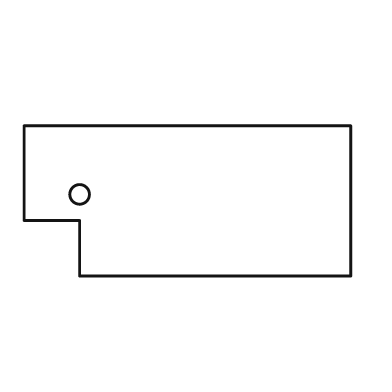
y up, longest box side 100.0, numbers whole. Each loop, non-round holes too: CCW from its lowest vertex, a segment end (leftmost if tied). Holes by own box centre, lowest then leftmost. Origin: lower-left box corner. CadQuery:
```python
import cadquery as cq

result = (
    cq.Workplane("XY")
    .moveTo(17.0, 0.0)
    .lineTo(100.0, 0.0)
    .lineTo(100.0, 46.0)
    .lineTo(0.0, 46.0)
    .lineTo(0.0, 17.0)
    .lineTo(17.0, 17.0)
    .close()
    .moveTo(17.0, 25.0)
    .circle(3.0)
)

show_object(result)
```